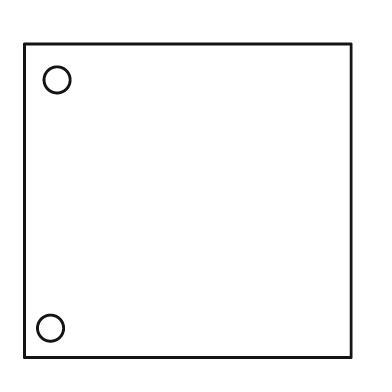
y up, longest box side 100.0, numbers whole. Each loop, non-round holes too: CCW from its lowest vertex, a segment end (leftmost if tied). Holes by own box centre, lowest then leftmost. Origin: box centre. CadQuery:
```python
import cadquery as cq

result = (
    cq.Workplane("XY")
    .moveTo(-50.0, -48.0)
    .lineTo(50.0, -48.0)
    .lineTo(50.0, 48.0)
    .lineTo(-50.0, 48.0)
    .close()
    .moveTo(-42.0, -39.0)
    .circle(4.0)
    .moveTo(-40.0, 37.0)
    .circle(4.0)
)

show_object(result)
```